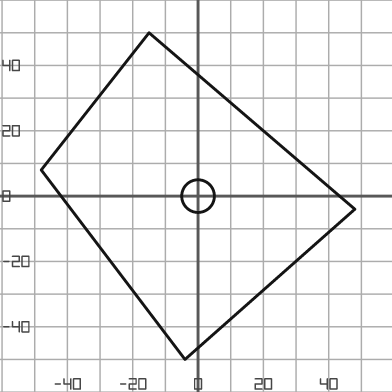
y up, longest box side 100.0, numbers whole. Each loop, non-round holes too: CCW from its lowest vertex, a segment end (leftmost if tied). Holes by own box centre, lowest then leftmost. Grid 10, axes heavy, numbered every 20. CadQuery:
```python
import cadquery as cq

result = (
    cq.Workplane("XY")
    .moveTo(-4.0, -50.0)
    .lineTo(48.0, -4.0)
    .lineTo(-15.0, 50.0)
    .lineTo(-48.0, 8.0)
    .close()
    .moveTo(0.0, 0.0)
    .circle(5.0)
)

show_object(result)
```